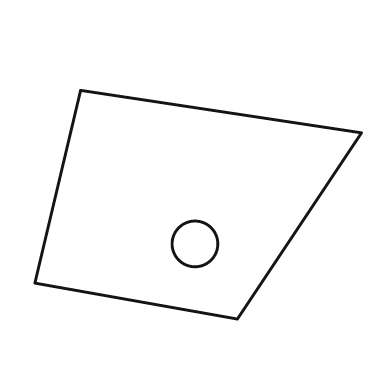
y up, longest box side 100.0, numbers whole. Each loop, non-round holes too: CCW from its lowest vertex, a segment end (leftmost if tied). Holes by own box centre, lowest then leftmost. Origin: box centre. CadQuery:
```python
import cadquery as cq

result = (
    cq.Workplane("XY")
    .moveTo(12.0, -35.0)
    .lineTo(50.0, 22.0)
    .lineTo(-36.0, 35.0)
    .lineTo(-50.0, -24.0)
    .close()
    .moveTo(-1.0, -12.0)
    .circle(7.0)
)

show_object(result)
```